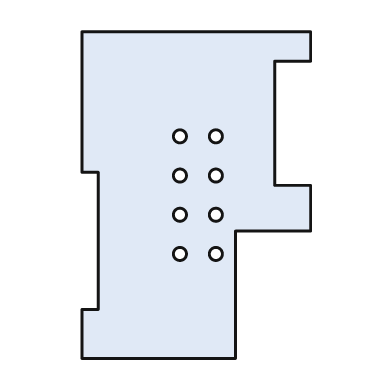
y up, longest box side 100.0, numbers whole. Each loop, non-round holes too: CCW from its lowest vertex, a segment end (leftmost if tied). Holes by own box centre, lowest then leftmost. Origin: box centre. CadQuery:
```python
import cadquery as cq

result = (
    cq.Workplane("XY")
    .moveTo(-35.0, -50.0)
    .lineTo(12.0, -50.0)
    .lineTo(12.0, -11.0)
    .lineTo(35.0, -11.0)
    .lineTo(35.0, 3.0)
    .lineTo(24.0, 3.0)
    .lineTo(24.0, 41.0)
    .lineTo(35.0, 41.0)
    .lineTo(35.0, 50.0)
    .lineTo(-35.0, 50.0)
    .lineTo(-35.0, 7.0)
    .lineTo(-30.0, 7.0)
    .lineTo(-30.0, -35.0)
    .lineTo(-35.0, -35.0)
    .close()
    .moveTo(-5.0, -18.0)
    .circle(2.0)
    .moveTo(6.0, -18.0)
    .circle(2.0)
    .moveTo(-5.0, -6.0)
    .circle(2.0)
    .moveTo(6.0, -6.0)
    .circle(2.0)
    .moveTo(-5.0, 6.0)
    .circle(2.0)
    .moveTo(6.0, 6.0)
    .circle(2.0)
    .moveTo(-5.0, 18.0)
    .circle(2.0)
    .moveTo(6.0, 18.0)
    .circle(2.0)
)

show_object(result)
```